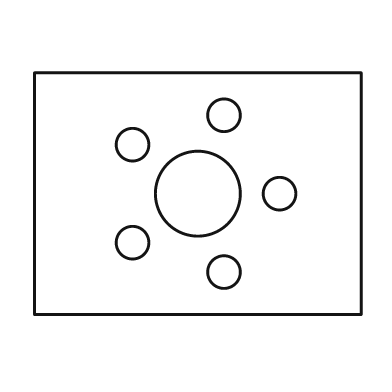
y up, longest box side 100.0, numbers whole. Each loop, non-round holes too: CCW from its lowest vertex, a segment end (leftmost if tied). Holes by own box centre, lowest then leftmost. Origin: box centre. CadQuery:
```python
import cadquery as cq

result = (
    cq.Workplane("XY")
    .moveTo(-50.0, -37.0)
    .lineTo(50.0, -37.0)
    .lineTo(50.0, 37.0)
    .lineTo(-50.0, 37.0)
    .close()
    .moveTo(8.0, -24.0)
    .circle(5.0)
    .moveTo(-20.0, -15.0)
    .circle(5.0)
    .moveTo(0.0, 0.0)
    .circle(13.0)
    .moveTo(25.0, 0.0)
    .circle(5.0)
    .moveTo(-20.0, 15.0)
    .circle(5.0)
    .moveTo(8.0, 24.0)
    .circle(5.0)
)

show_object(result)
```